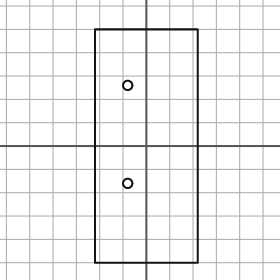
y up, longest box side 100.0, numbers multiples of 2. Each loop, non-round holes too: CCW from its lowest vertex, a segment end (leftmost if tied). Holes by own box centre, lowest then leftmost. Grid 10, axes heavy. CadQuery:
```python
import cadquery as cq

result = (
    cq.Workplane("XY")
    .moveTo(-22.0, -50.0)
    .lineTo(22.0, -50.0)
    .lineTo(22.0, 50.0)
    .lineTo(-22.0, 50.0)
    .close()
    .moveTo(-8.0, -16.0)
    .circle(2.0)
    .moveTo(-8.0, 26.0)
    .circle(2.0)
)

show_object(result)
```